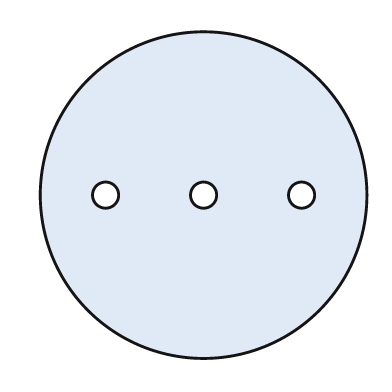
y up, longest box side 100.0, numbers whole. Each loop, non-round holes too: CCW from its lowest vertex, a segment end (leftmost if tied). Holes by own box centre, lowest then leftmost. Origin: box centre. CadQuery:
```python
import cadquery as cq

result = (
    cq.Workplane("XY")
    .moveTo(0.0, 0.0)
    .circle(50.0)
    .moveTo(-30.0, 0.0)
    .circle(4.0)
    .moveTo(0.0, 0.0)
    .circle(4.0)
    .moveTo(30.0, 0.0)
    .circle(4.0)
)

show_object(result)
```